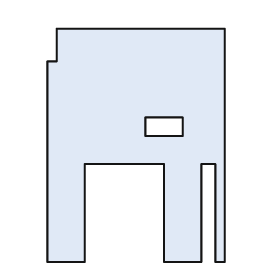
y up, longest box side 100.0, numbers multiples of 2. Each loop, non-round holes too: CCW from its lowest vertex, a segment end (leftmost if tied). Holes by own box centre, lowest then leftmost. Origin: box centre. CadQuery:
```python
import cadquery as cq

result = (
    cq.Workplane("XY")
    .moveTo(-38.0, -50.0)
    .lineTo(-22.0, -50.0)
    .lineTo(-22.0, -8.0)
    .lineTo(12.0, -8.0)
    .lineTo(12.0, -50.0)
    .lineTo(28.0, -50.0)
    .lineTo(28.0, -8.0)
    .lineTo(34.0, -8.0)
    .lineTo(34.0, -50.0)
    .lineTo(38.0, -50.0)
    .lineTo(38.0, 50.0)
    .lineTo(-34.0, 50.0)
    .lineTo(-34.0, 36.0)
    .lineTo(-38.0, 36.0)
    .close()
    .moveTo(4.0, 4.0)
    .lineTo(20.0, 4.0)
    .lineTo(20.0, 12.0)
    .lineTo(4.0, 12.0)
    .close()
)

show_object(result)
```